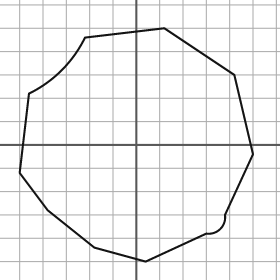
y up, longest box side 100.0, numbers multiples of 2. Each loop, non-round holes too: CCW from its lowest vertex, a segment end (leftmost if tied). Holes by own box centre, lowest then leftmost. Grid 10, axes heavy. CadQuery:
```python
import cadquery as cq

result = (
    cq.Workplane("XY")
    .moveTo(4.0, -50.0)
    .lineTo(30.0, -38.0)
    .threePointArc((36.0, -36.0), (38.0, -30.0))
    .lineTo(50.0, -4.0)
    .lineTo(42.0, 30.0)
    .lineTo(12.0, 50.0)
    .lineTo(-22.0, 46.0)
    .threePointArc((-32.0, 32.0), (-46.0, 22.0))
    .lineTo(-50.0, -12.0)
    .lineTo(-38.0, -28.0)
    .lineTo(-18.0, -44.0)
    .close()
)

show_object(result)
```